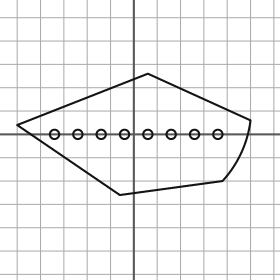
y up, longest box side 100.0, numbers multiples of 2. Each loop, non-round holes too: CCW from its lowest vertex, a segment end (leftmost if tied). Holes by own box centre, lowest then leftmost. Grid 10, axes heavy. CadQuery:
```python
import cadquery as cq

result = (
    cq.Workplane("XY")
    .moveTo(-6.0, -26.0)
    .lineTo(38.0, -20.0)
    .threePointArc((46.0, -8.0), (50.0, 6.0))
    .lineTo(6.0, 26.0)
    .lineTo(-50.0, 4.0)
    .close()
    .moveTo(-34.0, 0.0)
    .circle(2.0)
    .moveTo(-24.0, 0.0)
    .circle(2.0)
    .moveTo(-14.0, 0.0)
    .circle(2.0)
    .moveTo(-4.0, 0.0)
    .circle(2.0)
    .moveTo(6.0, 0.0)
    .circle(2.0)
    .moveTo(16.0, 0.0)
    .circle(2.0)
    .moveTo(26.0, 0.0)
    .circle(2.0)
    .moveTo(36.0, 0.0)
    .circle(2.0)
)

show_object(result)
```